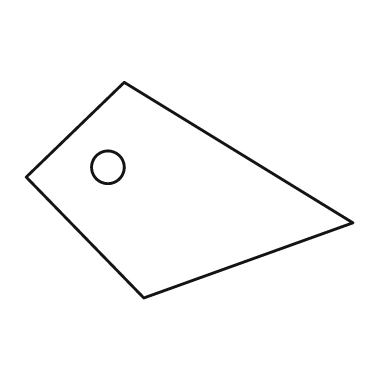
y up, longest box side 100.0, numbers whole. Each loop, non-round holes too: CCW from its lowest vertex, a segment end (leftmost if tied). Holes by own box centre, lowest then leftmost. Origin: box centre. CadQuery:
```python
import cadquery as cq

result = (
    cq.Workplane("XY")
    .moveTo(-14.0, -33.0)
    .lineTo(50.0, -10.0)
    .lineTo(-20.0, 33.0)
    .lineTo(-50.0, 4.0)
    .close()
    .moveTo(-25.0, 7.0)
    .circle(5.0)
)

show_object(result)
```